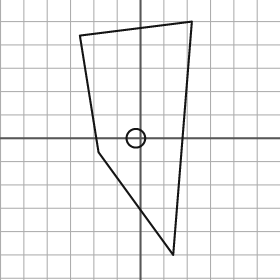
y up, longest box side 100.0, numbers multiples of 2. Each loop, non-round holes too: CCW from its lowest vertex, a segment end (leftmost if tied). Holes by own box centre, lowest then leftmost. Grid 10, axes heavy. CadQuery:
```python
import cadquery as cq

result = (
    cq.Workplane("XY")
    .moveTo(14.0, -50.0)
    .lineTo(22.0, 50.0)
    .lineTo(-26.0, 44.0)
    .lineTo(-18.0, -6.0)
    .close()
    .moveTo(-2.0, 0.0)
    .circle(4.0)
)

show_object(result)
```